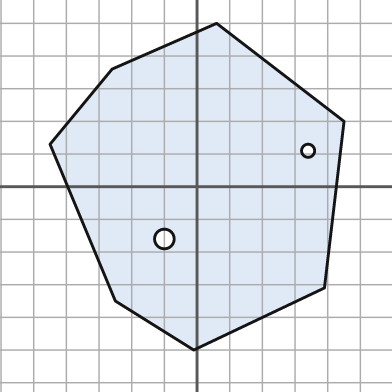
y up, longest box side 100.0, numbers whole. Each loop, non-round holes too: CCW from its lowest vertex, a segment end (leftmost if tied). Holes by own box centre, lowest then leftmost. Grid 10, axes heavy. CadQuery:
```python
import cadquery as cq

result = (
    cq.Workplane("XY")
    .moveTo(-1.0, -50.0)
    .lineTo(39.0, -31.0)
    .lineTo(45.0, 20.0)
    .lineTo(6.0, 50.0)
    .lineTo(-26.0, 36.0)
    .lineTo(-45.0, 13.0)
    .lineTo(-25.0, -35.0)
    .close()
    .moveTo(-10.0, -16.0)
    .circle(3.0)
    .moveTo(34.0, 11.0)
    .circle(2.0)
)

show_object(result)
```